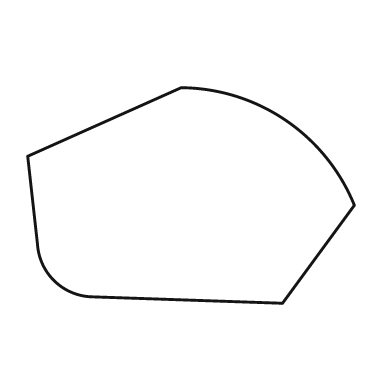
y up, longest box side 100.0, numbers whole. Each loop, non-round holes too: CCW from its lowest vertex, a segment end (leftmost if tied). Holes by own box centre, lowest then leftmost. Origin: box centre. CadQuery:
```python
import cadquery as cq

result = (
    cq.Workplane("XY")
    .moveTo(28.0, -33.0)
    .lineTo(50.0, -3.0)
    .threePointArc((29.0, 23.0), (-3.0, 33.0))
    .lineTo(-50.0, 12.0)
    .lineTo(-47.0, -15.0)
    .threePointArc((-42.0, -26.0), (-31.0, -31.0))
    .close()
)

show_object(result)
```